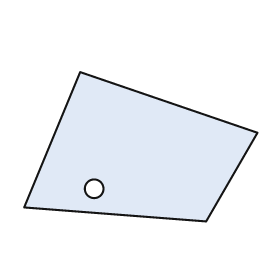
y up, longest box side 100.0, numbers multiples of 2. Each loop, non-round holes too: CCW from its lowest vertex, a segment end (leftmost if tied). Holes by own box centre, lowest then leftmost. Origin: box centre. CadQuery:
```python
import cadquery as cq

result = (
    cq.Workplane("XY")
    .moveTo(28.0, -32.0)
    .lineTo(50.0, 6.0)
    .lineTo(-26.0, 32.0)
    .lineTo(-50.0, -26.0)
    .close()
    .moveTo(-20.0, -18.0)
    .circle(4.0)
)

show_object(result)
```